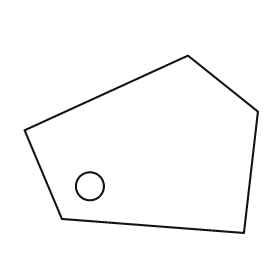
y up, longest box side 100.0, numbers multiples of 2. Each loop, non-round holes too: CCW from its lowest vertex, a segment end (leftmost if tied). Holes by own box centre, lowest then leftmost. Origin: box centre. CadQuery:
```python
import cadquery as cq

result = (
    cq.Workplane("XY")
    .moveTo(44.0, -38.0)
    .lineTo(50.0, 14.0)
    .lineTo(20.0, 38.0)
    .lineTo(-50.0, 6.0)
    .lineTo(-34.0, -32.0)
    .close()
    .moveTo(-22.0, -18.0)
    .circle(6.0)
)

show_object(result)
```